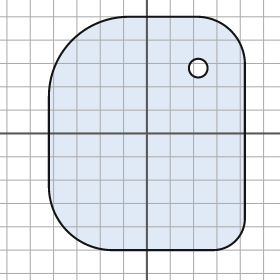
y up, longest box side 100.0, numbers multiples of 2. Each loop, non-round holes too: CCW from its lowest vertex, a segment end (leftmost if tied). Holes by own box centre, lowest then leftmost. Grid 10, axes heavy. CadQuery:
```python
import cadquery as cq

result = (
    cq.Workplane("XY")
    .moveTo(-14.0, -50.0)
    .lineTo(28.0, -50.0)
    .threePointArc((38.0, -46.0), (42.0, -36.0))
    .lineTo(42.0, 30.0)
    .threePointArc((36.0, 44.0), (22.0, 50.0))
    .lineTo(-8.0, 50.0)
    .threePointArc((-32.0, 40.0), (-42.0, 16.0))
    .lineTo(-42.0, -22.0)
    .threePointArc((-34.0, -42.0), (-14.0, -50.0))
    .close()
    .moveTo(22.0, 28.0)
    .circle(4.0)
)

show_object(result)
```